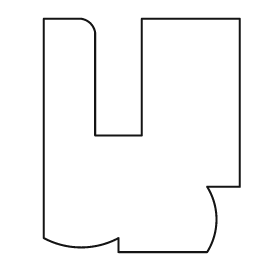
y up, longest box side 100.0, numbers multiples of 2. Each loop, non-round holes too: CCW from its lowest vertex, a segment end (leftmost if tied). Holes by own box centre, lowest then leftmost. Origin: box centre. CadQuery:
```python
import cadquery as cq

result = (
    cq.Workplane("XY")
    .moveTo(-10.0, -50.0)
    .lineTo(28.0, -50.0)
    .threePointArc((32.0, -36.0), (28.0, -22.0))
    .lineTo(42.0, -22.0)
    .lineTo(42.0, 50.0)
    .lineTo(0.0, 50.0)
    .lineTo(0.0, 0.0)
    .lineTo(-20.0, 0.0)
    .lineTo(-20.0, 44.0)
    .threePointArc((-22.0, 48.0), (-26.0, 50.0))
    .lineTo(-42.0, 50.0)
    .lineTo(-42.0, -44.0)
    .threePointArc((-26.0, -48.0), (-10.0, -44.0))
    .close()
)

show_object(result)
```